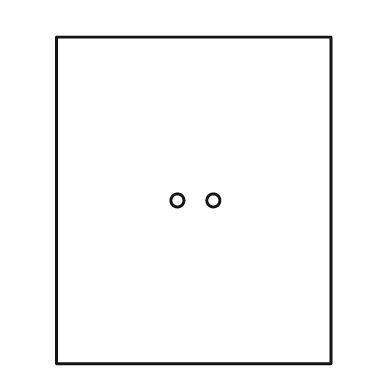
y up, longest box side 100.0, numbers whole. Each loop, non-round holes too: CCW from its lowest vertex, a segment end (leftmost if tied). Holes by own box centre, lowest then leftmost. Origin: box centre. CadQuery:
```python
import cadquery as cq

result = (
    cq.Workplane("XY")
    .moveTo(-42.0, -50.0)
    .lineTo(42.0, -50.0)
    .lineTo(42.0, 50.0)
    .lineTo(-42.0, 50.0)
    .close()
    .moveTo(-5.0, 0.0)
    .circle(2.0)
    .moveTo(6.0, 0.0)
    .circle(2.0)
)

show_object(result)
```